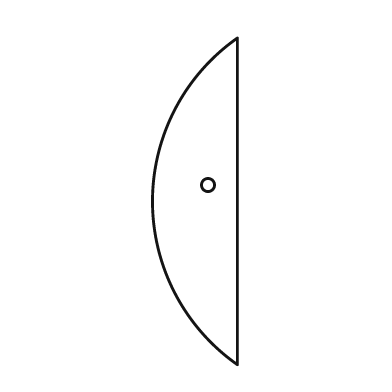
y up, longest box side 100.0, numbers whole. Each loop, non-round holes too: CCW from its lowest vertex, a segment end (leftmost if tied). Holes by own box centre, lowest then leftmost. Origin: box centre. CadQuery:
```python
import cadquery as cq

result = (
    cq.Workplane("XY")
    .moveTo(13.0, -50.0)
    .lineTo(13.0, 50.0)
    .threePointArc((-13.0, 0.0), (13.0, -50.0))
    .close()
    .moveTo(4.0, 5.0)
    .circle(2.0)
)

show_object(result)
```